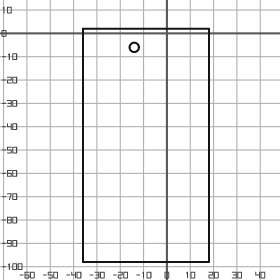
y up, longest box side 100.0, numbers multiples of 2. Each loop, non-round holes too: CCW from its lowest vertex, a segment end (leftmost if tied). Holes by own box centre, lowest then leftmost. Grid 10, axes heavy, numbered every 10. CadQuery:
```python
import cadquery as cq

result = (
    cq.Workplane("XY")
    .moveTo(-36.0, -98.0)
    .lineTo(18.0, -98.0)
    .lineTo(18.0, 2.0)
    .lineTo(-36.0, 2.0)
    .close()
    .moveTo(-14.0, -6.0)
    .circle(2.0)
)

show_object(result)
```